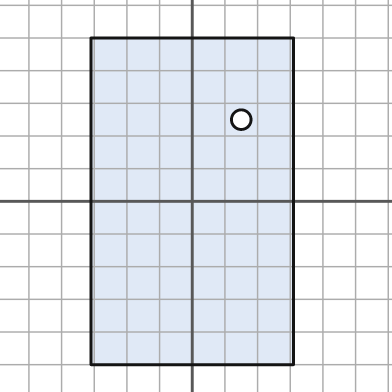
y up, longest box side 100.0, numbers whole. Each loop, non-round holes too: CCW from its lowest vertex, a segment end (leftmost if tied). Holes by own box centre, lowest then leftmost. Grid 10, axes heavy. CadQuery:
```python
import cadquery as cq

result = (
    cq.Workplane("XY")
    .moveTo(-31.0, -50.0)
    .lineTo(31.0, -50.0)
    .lineTo(31.0, 50.0)
    .lineTo(-31.0, 50.0)
    .close()
    .moveTo(15.0, 25.0)
    .circle(3.0)
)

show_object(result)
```